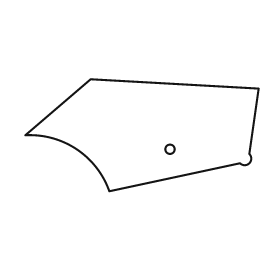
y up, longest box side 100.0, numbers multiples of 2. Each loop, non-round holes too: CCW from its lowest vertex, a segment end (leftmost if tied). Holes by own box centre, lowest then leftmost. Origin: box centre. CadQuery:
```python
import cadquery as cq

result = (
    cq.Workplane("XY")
    .moveTo(-14.0, -24.0)
    .lineTo(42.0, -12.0)
    .threePointArc((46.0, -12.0), (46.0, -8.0))
    .lineTo(50.0, 20.0)
    .lineTo(-22.0, 24.0)
    .lineTo(-50.0, 0.0)
    .threePointArc((-28.0, -6.0), (-14.0, -24.0))
    .close()
    .moveTo(12.0, -6.0)
    .circle(2.0)
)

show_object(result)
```